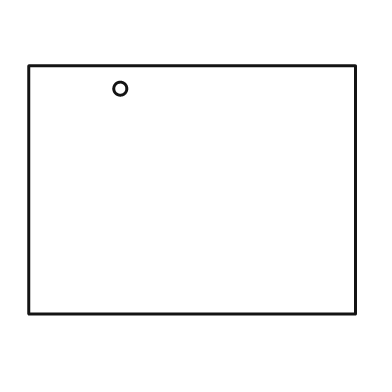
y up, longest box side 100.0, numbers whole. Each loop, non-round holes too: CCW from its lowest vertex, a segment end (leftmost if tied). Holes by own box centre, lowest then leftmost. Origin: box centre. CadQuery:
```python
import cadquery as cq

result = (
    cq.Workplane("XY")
    .moveTo(-50.0, -38.0)
    .lineTo(50.0, -38.0)
    .lineTo(50.0, 38.0)
    .lineTo(-50.0, 38.0)
    .close()
    .moveTo(-22.0, 31.0)
    .circle(2.0)
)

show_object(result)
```